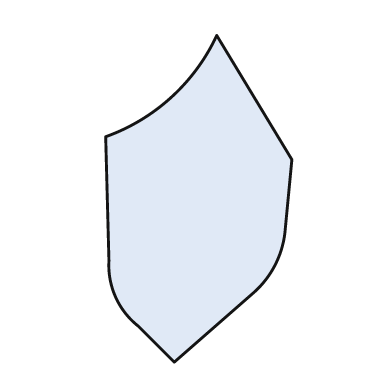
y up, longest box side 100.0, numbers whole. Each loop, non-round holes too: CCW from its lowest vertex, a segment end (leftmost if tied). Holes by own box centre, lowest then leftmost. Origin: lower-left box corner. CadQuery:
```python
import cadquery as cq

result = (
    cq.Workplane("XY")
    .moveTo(21.0, 0.0)
    .lineTo(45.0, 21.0)
    .threePointArc((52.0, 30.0), (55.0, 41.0))
    .lineTo(57.0, 62.0)
    .lineTo(34.0, 100.0)
    .threePointArc((20.0, 81.0), (0.0, 69.0))
    .lineTo(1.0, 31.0)
    .threePointArc((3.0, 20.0), (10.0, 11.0))
    .close()
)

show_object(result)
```